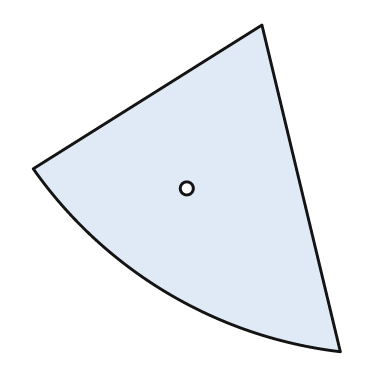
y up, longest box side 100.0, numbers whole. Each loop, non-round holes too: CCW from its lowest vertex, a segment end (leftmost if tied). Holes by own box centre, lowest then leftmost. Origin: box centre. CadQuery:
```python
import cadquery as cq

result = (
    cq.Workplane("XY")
    .moveTo(47.0, -50.0)
    .lineTo(23.0, 50.0)
    .lineTo(-47.0, 6.0)
    .threePointArc((-6.0, -32.0), (47.0, -50.0))
    .close()
    .moveTo(0.0, 0.0)
    .circle(2.0)
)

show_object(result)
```